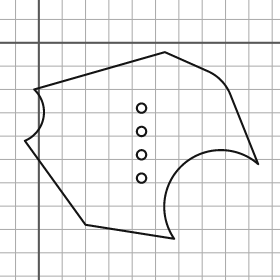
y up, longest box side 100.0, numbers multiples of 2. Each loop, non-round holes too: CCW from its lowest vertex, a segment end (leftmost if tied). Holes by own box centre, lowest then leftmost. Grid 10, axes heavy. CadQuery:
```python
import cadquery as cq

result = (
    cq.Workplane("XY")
    .moveTo(58.0, -84.0)
    .threePointArc((62.0, -52.0), (94.0, -52.0))
    .lineTo(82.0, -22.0)
    .threePointArc((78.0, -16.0), (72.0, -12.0))
    .lineTo(54.0, -4.0)
    .lineTo(-2.0, -20.0)
    .threePointArc((2.0, -32.0), (-6.0, -42.0))
    .lineTo(20.0, -78.0)
    .close()
    .moveTo(44.0, -58.0)
    .circle(2.0)
    .moveTo(44.0, -48.0)
    .circle(2.0)
    .moveTo(44.0, -38.0)
    .circle(2.0)
    .moveTo(44.0, -28.0)
    .circle(2.0)
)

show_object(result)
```